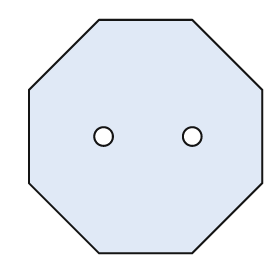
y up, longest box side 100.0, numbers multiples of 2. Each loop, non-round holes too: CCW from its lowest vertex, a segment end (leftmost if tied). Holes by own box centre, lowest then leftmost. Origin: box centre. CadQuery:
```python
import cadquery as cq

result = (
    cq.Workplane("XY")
    .moveTo(-20.0, -50.0)
    .lineTo(20.0, -50.0)
    .lineTo(50.0, -20.0)
    .lineTo(50.0, 20.0)
    .lineTo(20.0, 50.0)
    .lineTo(-20.0, 50.0)
    .lineTo(-50.0, 20.0)
    .lineTo(-50.0, -20.0)
    .close()
    .moveTo(-18.0, 0.0)
    .circle(4.0)
    .moveTo(20.0, 0.0)
    .circle(4.0)
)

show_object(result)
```